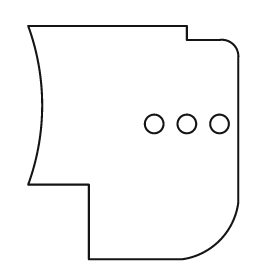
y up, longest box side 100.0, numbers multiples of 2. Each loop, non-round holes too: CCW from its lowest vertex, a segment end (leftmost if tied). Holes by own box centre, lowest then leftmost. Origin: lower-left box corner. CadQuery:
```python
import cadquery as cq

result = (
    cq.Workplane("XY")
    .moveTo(26.0, 0.0)
    .lineTo(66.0, 0.0)
    .threePointArc((82.0, 8.0), (90.0, 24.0))
    .lineTo(90.0, 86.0)
    .threePointArc((88.0, 92.0), (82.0, 94.0))
    .lineTo(68.0, 94.0)
    .lineTo(68.0, 100.0)
    .lineTo(0.0, 100.0)
    .threePointArc((6.0, 66.0), (0.0, 32.0))
    .lineTo(26.0, 32.0)
    .close()
    .moveTo(54.0, 58.0)
    .circle(4.0)
    .moveTo(68.0, 58.0)
    .circle(4.0)
    .moveTo(82.0, 58.0)
    .circle(4.0)
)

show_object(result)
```